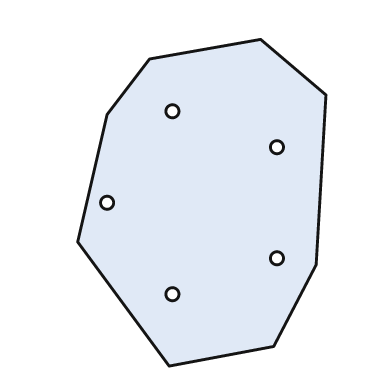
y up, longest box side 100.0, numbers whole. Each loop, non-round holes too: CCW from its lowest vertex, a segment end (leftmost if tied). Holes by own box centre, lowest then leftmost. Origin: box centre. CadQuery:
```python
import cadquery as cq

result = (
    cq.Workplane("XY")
    .moveTo(-10.0, -50.0)
    .lineTo(22.0, -44.0)
    .lineTo(35.0, -19.0)
    .lineTo(38.0, 33.0)
    .lineTo(18.0, 50.0)
    .lineTo(-16.0, 44.0)
    .lineTo(-29.0, 27.0)
    .lineTo(-38.0, -12.0)
    .close()
    .moveTo(-9.0, -28.0)
    .circle(2.0)
    .moveTo(23.0, -17.0)
    .circle(2.0)
    .moveTo(-29.0, 0.0)
    .circle(2.0)
    .moveTo(23.0, 17.0)
    .circle(2.0)
    .moveTo(-9.0, 28.0)
    .circle(2.0)
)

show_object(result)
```